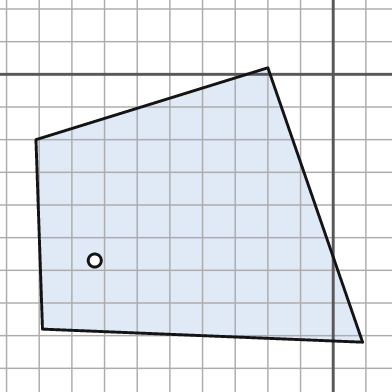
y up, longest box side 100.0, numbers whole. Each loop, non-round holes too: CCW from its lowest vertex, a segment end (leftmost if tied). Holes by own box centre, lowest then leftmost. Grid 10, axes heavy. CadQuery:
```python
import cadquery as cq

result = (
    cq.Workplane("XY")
    .moveTo(9.0, -82.0)
    .lineTo(-20.0, 2.0)
    .lineTo(-91.0, -20.0)
    .lineTo(-89.0, -78.0)
    .close()
    .moveTo(-73.0, -57.0)
    .circle(2.0)
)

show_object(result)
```